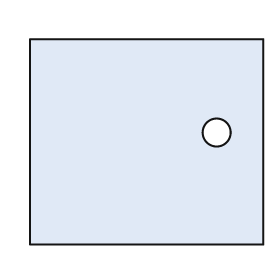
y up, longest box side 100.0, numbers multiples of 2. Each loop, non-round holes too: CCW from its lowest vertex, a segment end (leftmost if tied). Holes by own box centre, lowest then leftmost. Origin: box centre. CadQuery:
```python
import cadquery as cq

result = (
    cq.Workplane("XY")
    .moveTo(-50.0, -44.0)
    .lineTo(50.0, -44.0)
    .lineTo(50.0, 44.0)
    .lineTo(-50.0, 44.0)
    .close()
    .moveTo(30.0, 4.0)
    .circle(6.0)
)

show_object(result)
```